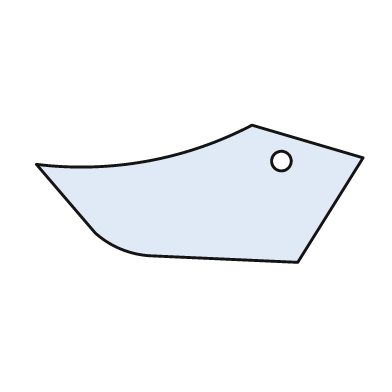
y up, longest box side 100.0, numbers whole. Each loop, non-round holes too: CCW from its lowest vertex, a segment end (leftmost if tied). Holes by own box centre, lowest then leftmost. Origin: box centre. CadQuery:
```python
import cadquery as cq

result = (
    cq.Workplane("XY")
    .moveTo(30.0, -21.0)
    .lineTo(50.0, 11.0)
    .lineTo(16.0, 21.0)
    .threePointArc((-16.0, 10.0), (-50.0, 9.0))
    .lineTo(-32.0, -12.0)
    .threePointArc((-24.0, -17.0), (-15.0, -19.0))
    .close()
    .moveTo(25.0, 10.0)
    .circle(3.0)
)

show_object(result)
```